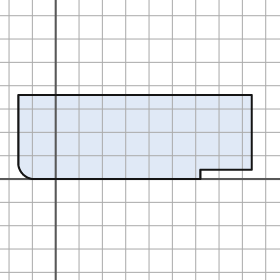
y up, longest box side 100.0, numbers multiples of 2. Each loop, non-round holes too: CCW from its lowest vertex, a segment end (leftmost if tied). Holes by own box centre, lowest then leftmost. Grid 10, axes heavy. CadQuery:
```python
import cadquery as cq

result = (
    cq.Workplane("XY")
    .moveTo(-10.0, 0.0)
    .lineTo(62.0, 0.0)
    .lineTo(62.0, 4.0)
    .lineTo(84.0, 4.0)
    .lineTo(84.0, 36.0)
    .lineTo(-16.0, 36.0)
    .lineTo(-16.0, 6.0)
    .threePointArc((-14.0, 2.0), (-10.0, 0.0))
    .close()
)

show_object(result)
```